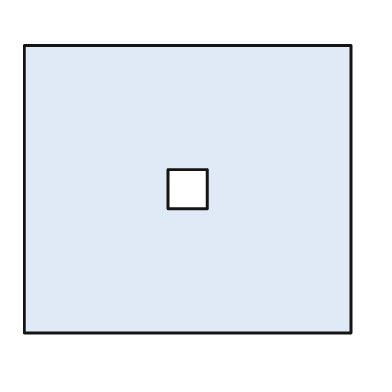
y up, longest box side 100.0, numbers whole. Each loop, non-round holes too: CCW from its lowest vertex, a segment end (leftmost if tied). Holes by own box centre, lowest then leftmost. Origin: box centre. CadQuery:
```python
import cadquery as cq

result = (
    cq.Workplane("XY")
    .moveTo(-50.0, -44.0)
    .lineTo(50.0, -44.0)
    .lineTo(50.0, 44.0)
    .lineTo(-50.0, 44.0)
    .close()
    .moveTo(-6.0, -6.0)
    .lineTo(6.0, -6.0)
    .lineTo(6.0, 6.0)
    .lineTo(-6.0, 6.0)
    .close()
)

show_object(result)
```